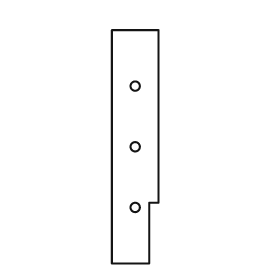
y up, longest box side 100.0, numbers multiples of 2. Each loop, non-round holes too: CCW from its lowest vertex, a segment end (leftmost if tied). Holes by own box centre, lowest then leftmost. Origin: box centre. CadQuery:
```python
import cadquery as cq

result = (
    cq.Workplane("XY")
    .moveTo(-10.0, -50.0)
    .lineTo(6.0, -50.0)
    .lineTo(6.0, -24.0)
    .lineTo(10.0, -24.0)
    .lineTo(10.0, 50.0)
    .lineTo(-10.0, 50.0)
    .close()
    .moveTo(0.0, -26.0)
    .circle(2.0)
    .moveTo(0.0, 0.0)
    .circle(2.0)
    .moveTo(0.0, 26.0)
    .circle(2.0)
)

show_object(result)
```